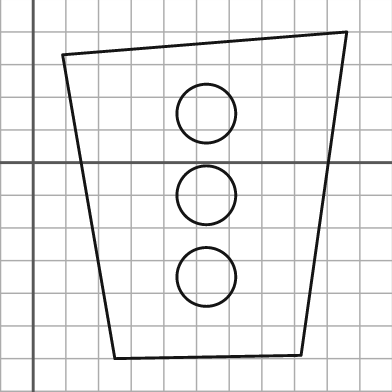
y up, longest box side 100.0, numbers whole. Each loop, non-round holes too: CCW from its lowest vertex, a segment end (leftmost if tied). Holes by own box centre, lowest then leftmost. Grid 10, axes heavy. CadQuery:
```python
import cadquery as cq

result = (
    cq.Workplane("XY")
    .moveTo(25.0, -60.0)
    .lineTo(82.0, -59.0)
    .lineTo(96.0, 40.0)
    .lineTo(9.0, 33.0)
    .close()
    .moveTo(53.0, -35.0)
    .circle(9.0)
    .moveTo(53.0, -10.0)
    .circle(9.0)
    .moveTo(53.0, 15.0)
    .circle(9.0)
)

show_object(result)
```